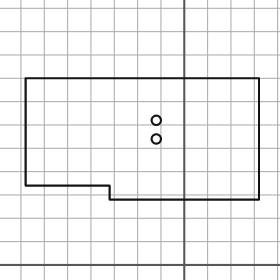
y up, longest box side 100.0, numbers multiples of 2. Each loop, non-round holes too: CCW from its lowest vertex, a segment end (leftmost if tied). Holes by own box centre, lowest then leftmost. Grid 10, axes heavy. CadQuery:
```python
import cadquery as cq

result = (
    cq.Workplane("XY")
    .moveTo(-32.0, 28.0)
    .lineTo(32.0, 28.0)
    .lineTo(32.0, 80.0)
    .lineTo(-68.0, 80.0)
    .lineTo(-68.0, 34.0)
    .lineTo(-32.0, 34.0)
    .close()
    .moveTo(-12.0, 54.0)
    .circle(2.0)
    .moveTo(-12.0, 62.0)
    .circle(2.0)
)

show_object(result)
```